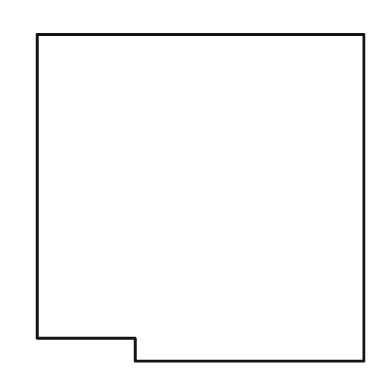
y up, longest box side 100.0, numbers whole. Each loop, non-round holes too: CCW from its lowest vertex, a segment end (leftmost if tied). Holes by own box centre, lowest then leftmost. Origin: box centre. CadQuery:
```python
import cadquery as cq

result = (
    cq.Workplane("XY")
    .moveTo(-20.0, -50.0)
    .lineTo(50.0, -50.0)
    .lineTo(50.0, 50.0)
    .lineTo(-50.0, 50.0)
    .lineTo(-50.0, -43.0)
    .lineTo(-20.0, -43.0)
    .close()
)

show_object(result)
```